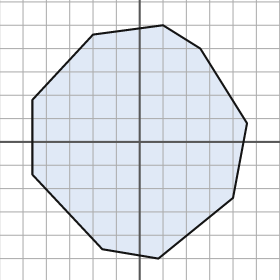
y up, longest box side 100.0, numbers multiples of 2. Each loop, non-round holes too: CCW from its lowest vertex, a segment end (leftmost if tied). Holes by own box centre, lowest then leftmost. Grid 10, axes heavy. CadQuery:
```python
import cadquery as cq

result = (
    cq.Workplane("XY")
    .moveTo(8.0, -50.0)
    .lineTo(40.0, -24.0)
    .lineTo(46.0, 8.0)
    .lineTo(26.0, 40.0)
    .lineTo(10.0, 50.0)
    .lineTo(-20.0, 46.0)
    .lineTo(-46.0, 18.0)
    .lineTo(-46.0, -14.0)
    .lineTo(-16.0, -46.0)
    .close()
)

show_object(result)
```